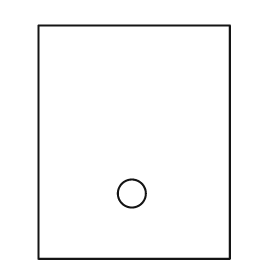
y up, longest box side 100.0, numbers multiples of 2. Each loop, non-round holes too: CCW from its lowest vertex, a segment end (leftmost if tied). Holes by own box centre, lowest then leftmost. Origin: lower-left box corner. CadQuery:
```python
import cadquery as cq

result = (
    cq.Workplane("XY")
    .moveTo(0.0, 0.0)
    .lineTo(82.0, 0.0)
    .lineTo(82.0, 100.0)
    .lineTo(0.0, 100.0)
    .close()
    .moveTo(40.0, 28.0)
    .circle(6.0)
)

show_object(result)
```